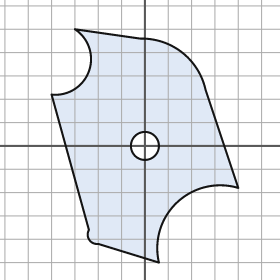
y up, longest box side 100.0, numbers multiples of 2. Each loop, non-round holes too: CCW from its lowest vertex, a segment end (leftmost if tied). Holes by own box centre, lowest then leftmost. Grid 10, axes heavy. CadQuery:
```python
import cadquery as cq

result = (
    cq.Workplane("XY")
    .moveTo(6.0, -50.0)
    .threePointArc((14.0, -24.0), (40.0, -18.0))
    .lineTo(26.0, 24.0)
    .threePointArc((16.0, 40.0), (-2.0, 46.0))
    .lineTo(-30.0, 50.0)
    .threePointArc((-24.0, 32.0), (-40.0, 22.0))
    .lineTo(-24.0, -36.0)
    .threePointArc((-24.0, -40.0), (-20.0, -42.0))
    .close()
    .moveTo(0.0, 0.0)
    .circle(6.0)
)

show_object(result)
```